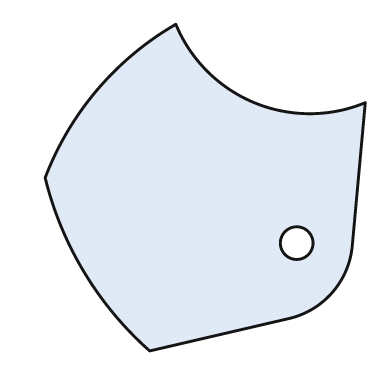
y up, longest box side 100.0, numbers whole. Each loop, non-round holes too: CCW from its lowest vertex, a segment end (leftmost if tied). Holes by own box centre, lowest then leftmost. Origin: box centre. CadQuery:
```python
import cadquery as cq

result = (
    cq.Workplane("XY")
    .moveTo(-17.0, -50.0)
    .lineTo(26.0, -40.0)
    .threePointArc((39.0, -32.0), (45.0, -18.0))
    .lineTo(49.0, 26.0)
    .threePointArc((15.0, 26.0), (-9.0, 50.0))
    .threePointArc((-33.0, 30.0), (-49.0, 3.0))
    .threePointArc((-37.0, -26.0), (-17.0, -50.0))
    .close()
    .moveTo(28.0, -17.0)
    .circle(5.0)
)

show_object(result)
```